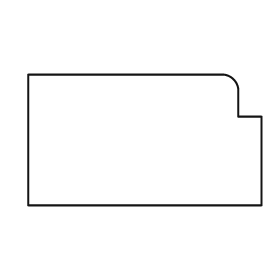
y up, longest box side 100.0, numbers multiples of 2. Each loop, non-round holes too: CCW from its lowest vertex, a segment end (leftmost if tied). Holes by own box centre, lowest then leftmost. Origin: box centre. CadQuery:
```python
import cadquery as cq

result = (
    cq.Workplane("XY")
    .moveTo(-50.0, -28.0)
    .lineTo(50.0, -28.0)
    .lineTo(50.0, 10.0)
    .lineTo(40.0, 10.0)
    .lineTo(40.0, 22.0)
    .threePointArc((38.0, 26.0), (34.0, 28.0))
    .lineTo(-50.0, 28.0)
    .close()
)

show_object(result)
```